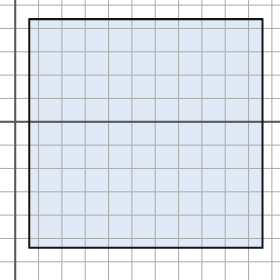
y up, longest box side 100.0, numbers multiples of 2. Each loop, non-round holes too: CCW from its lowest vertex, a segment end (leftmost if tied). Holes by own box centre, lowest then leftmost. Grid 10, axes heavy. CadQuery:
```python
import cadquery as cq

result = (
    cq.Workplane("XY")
    .moveTo(6.0, -54.0)
    .lineTo(106.0, -54.0)
    .lineTo(106.0, 44.0)
    .lineTo(6.0, 44.0)
    .close()
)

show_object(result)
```